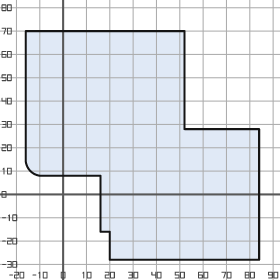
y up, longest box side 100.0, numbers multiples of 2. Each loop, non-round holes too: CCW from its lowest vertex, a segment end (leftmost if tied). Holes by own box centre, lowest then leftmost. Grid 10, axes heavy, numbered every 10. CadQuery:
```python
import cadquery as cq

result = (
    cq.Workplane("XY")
    .moveTo(20.0, -28.0)
    .lineTo(84.0, -28.0)
    .lineTo(84.0, 28.0)
    .lineTo(52.0, 28.0)
    .lineTo(52.0, 70.0)
    .lineTo(-16.0, 70.0)
    .lineTo(-16.0, 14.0)
    .threePointArc((-14.0, 10.0), (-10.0, 8.0))
    .lineTo(16.0, 8.0)
    .lineTo(16.0, -16.0)
    .lineTo(20.0, -16.0)
    .close()
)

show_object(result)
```